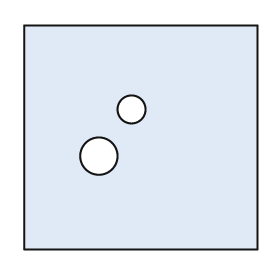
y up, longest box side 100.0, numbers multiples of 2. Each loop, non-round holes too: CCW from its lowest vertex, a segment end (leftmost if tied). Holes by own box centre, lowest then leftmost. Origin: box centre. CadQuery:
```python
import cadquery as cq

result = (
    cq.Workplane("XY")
    .moveTo(-50.0, -48.0)
    .lineTo(50.0, -48.0)
    .lineTo(50.0, 48.0)
    .lineTo(-50.0, 48.0)
    .close()
    .moveTo(-18.0, -8.0)
    .circle(8.0)
    .moveTo(-4.0, 12.0)
    .circle(6.0)
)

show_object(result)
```